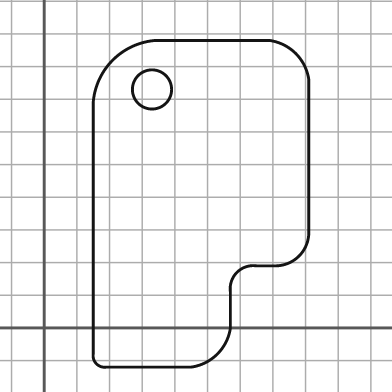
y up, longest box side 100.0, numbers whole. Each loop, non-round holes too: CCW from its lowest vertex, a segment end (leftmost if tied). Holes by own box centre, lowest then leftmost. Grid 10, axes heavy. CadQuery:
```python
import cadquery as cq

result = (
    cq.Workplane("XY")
    .moveTo(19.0, -12.0)
    .lineTo(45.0, -12.0)
    .threePointArc((53.0, -8.0), (57.0, 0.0))
    .lineTo(57.0, 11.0)
    .threePointArc((59.0, 17.0), (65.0, 19.0))
    .lineTo(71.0, 19.0)
    .threePointArc((78.0, 22.0), (81.0, 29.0))
    .lineTo(81.0, 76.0)
    .threePointArc((77.0, 84.0), (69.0, 88.0))
    .lineTo(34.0, 88.0)
    .threePointArc((21.0, 82.0), (15.0, 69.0))
    .lineTo(15.0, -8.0)
    .threePointArc((16.0, -11.0), (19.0, -12.0))
    .close()
    .moveTo(33.0, 73.0)
    .circle(6.0)
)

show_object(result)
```